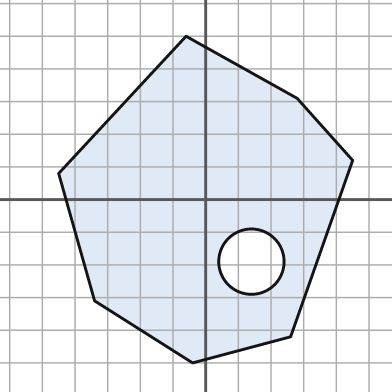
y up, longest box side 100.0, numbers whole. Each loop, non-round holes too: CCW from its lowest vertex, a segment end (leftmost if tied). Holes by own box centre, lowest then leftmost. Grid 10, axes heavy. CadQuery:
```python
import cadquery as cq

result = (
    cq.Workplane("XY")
    .moveTo(-4.0, -50.0)
    .lineTo(26.0, -42.0)
    .lineTo(45.0, 12.0)
    .lineTo(28.0, 31.0)
    .lineTo(-6.0, 50.0)
    .lineTo(-45.0, 8.0)
    .lineTo(-34.0, -31.0)
    .close()
    .moveTo(14.0, -19.0)
    .circle(10.0)
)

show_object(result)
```